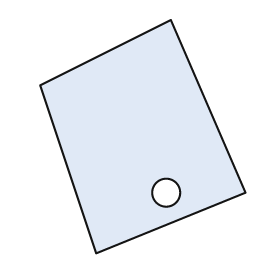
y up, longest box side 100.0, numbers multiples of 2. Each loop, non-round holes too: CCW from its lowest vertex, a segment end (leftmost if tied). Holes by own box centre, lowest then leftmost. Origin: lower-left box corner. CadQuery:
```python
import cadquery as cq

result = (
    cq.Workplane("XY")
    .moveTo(24.0, 0.0)
    .lineTo(88.0, 26.0)
    .lineTo(56.0, 100.0)
    .lineTo(0.0, 72.0)
    .close()
    .moveTo(54.0, 26.0)
    .circle(6.0)
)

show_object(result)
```